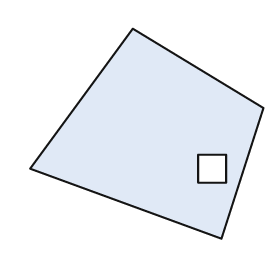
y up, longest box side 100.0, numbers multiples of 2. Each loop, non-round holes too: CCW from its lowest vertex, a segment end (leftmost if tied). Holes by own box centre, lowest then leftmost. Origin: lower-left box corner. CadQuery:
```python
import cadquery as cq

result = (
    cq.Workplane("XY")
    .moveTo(82.0, 0.0)
    .lineTo(100.0, 56.0)
    .lineTo(44.0, 90.0)
    .lineTo(0.0, 30.0)
    .close()
    .moveTo(72.0, 24.0)
    .lineTo(84.0, 24.0)
    .lineTo(84.0, 36.0)
    .lineTo(72.0, 36.0)
    .close()
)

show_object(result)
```